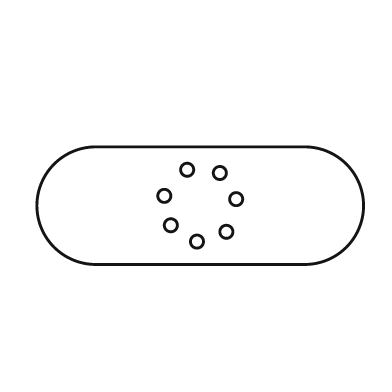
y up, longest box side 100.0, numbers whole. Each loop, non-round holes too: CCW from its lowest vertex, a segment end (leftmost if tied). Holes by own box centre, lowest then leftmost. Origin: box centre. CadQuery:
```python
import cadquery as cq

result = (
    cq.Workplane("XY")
    .moveTo(-32.0, -18.0)
    .lineTo(32.0, -18.0)
    .threePointArc((50.0, 0.0), (32.0, 18.0))
    .lineTo(-32.0, 18.0)
    .threePointArc((-50.0, 0.0), (-32.0, -18.0))
    .close()
    .moveTo(-1.0, -11.0)
    .circle(2.0)
    .moveTo(8.0, -8.0)
    .circle(2.0)
    .moveTo(-9.0, -6.0)
    .circle(2.0)
    .moveTo(11.0, 2.0)
    .circle(2.0)
    .moveTo(-11.0, 3.0)
    .circle(2.0)
    .moveTo(6.0, 10.0)
    .circle(2.0)
    .moveTo(-4.0, 11.0)
    .circle(2.0)
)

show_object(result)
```